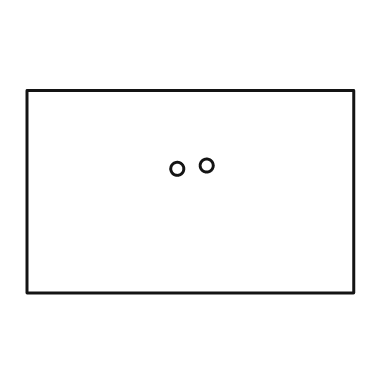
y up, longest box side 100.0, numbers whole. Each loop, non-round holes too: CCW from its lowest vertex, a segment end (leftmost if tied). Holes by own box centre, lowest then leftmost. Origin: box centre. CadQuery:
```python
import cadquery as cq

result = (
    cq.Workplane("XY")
    .moveTo(-50.0, -31.0)
    .lineTo(50.0, -31.0)
    .lineTo(50.0, 31.0)
    .lineTo(-50.0, 31.0)
    .close()
    .moveTo(-4.0, 7.0)
    .circle(2.0)
    .moveTo(5.0, 8.0)
    .circle(2.0)
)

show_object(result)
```